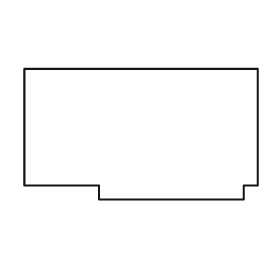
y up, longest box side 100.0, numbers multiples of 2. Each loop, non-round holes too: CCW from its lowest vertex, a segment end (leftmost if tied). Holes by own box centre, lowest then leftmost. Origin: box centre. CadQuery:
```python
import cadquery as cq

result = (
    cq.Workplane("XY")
    .moveTo(-18.0, -28.0)
    .lineTo(44.0, -28.0)
    .lineTo(44.0, -22.0)
    .lineTo(50.0, -22.0)
    .lineTo(50.0, 28.0)
    .lineTo(-50.0, 28.0)
    .lineTo(-50.0, -22.0)
    .lineTo(-18.0, -22.0)
    .close()
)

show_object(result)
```